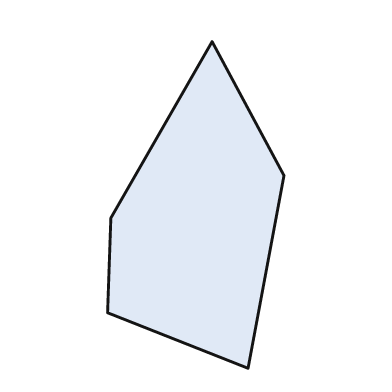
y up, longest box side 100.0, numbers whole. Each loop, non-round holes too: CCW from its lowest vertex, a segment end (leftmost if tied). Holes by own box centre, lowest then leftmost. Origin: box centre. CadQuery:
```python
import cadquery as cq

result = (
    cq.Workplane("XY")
    .moveTo(16.0, -50.0)
    .lineTo(27.0, 9.0)
    .lineTo(5.0, 50.0)
    .lineTo(-26.0, -4.0)
    .lineTo(-27.0, -33.0)
    .close()
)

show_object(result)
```